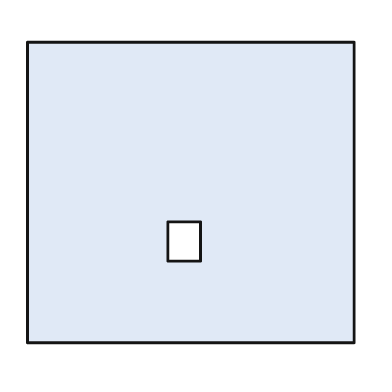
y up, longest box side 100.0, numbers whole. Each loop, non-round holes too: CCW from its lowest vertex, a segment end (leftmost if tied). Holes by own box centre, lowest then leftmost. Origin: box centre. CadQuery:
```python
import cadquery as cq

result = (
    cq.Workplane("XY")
    .moveTo(-50.0, -46.0)
    .lineTo(50.0, -46.0)
    .lineTo(50.0, 46.0)
    .lineTo(-50.0, 46.0)
    .close()
    .moveTo(-7.0, -21.0)
    .lineTo(3.0, -21.0)
    .lineTo(3.0, -9.0)
    .lineTo(-7.0, -9.0)
    .close()
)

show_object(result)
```